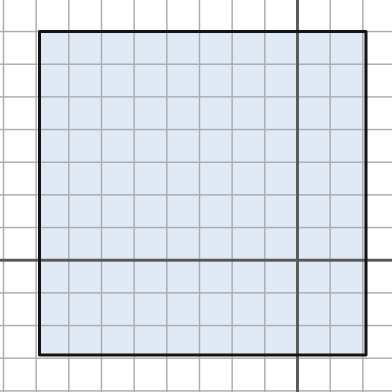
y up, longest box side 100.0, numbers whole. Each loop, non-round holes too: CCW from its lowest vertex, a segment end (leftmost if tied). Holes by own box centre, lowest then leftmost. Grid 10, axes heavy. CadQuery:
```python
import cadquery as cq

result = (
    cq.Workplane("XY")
    .moveTo(-79.0, -29.0)
    .lineTo(21.0, -29.0)
    .lineTo(21.0, 70.0)
    .lineTo(-79.0, 70.0)
    .close()
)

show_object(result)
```